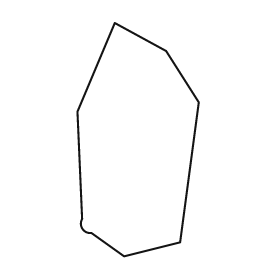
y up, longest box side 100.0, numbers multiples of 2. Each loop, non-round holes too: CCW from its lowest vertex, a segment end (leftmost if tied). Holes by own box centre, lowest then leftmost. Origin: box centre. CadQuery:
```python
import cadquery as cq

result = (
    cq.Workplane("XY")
    .moveTo(-6.0, -50.0)
    .lineTo(18.0, -44.0)
    .lineTo(26.0, 16.0)
    .lineTo(12.0, 38.0)
    .lineTo(-10.0, 50.0)
    .lineTo(-26.0, 12.0)
    .lineTo(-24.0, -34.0)
    .threePointArc((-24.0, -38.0), (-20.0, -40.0))
    .close()
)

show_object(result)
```